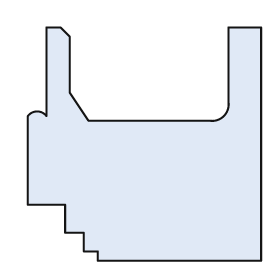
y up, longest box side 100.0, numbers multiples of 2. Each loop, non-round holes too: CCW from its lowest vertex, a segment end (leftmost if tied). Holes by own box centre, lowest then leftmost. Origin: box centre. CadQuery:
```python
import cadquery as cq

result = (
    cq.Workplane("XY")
    .moveTo(-20.0, -50.0)
    .lineTo(50.0, -50.0)
    .lineTo(50.0, 50.0)
    .lineTo(36.0, 50.0)
    .lineTo(36.0, 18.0)
    .threePointArc((34.0, 12.0), (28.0, 10.0))
    .lineTo(-24.0, 10.0)
    .lineTo(-32.0, 22.0)
    .lineTo(-32.0, 46.0)
    .lineTo(-36.0, 50.0)
    .lineTo(-42.0, 50.0)
    .lineTo(-42.0, 12.0)
    .threePointArc((-46.0, 14.0), (-50.0, 12.0))
    .lineTo(-50.0, -26.0)
    .lineTo(-34.0, -26.0)
    .lineTo(-34.0, -38.0)
    .lineTo(-26.0, -38.0)
    .lineTo(-26.0, -46.0)
    .lineTo(-20.0, -46.0)
    .close()
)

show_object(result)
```